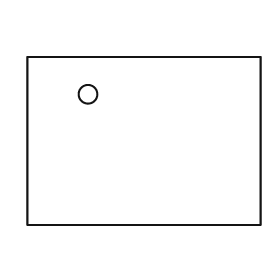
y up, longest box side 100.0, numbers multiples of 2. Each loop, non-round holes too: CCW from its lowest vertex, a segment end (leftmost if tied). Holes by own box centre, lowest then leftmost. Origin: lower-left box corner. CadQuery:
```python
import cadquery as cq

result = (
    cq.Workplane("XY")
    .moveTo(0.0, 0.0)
    .lineTo(100.0, 0.0)
    .lineTo(100.0, 72.0)
    .lineTo(0.0, 72.0)
    .close()
    .moveTo(26.0, 56.0)
    .circle(4.0)
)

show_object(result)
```